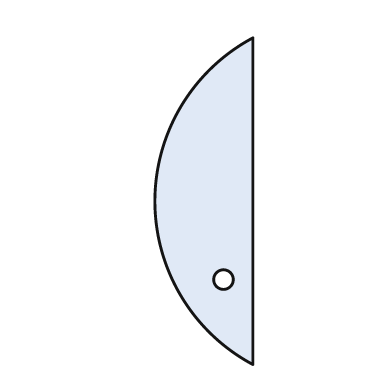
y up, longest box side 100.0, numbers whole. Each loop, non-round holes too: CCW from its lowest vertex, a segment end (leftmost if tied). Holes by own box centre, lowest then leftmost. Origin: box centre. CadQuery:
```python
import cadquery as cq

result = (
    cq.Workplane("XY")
    .moveTo(15.0, -50.0)
    .lineTo(15.0, 50.0)
    .threePointArc((-15.0, 0.0), (15.0, -50.0))
    .close()
    .moveTo(6.0, -24.0)
    .circle(3.0)
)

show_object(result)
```